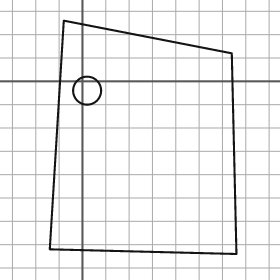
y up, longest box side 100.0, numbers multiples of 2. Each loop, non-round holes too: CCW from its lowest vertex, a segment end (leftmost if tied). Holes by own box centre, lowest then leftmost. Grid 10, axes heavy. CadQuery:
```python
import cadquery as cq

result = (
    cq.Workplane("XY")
    .moveTo(66.0, -74.0)
    .lineTo(64.0, 12.0)
    .lineTo(-8.0, 26.0)
    .lineTo(-14.0, -72.0)
    .close()
    .moveTo(2.0, -4.0)
    .circle(6.0)
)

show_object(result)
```